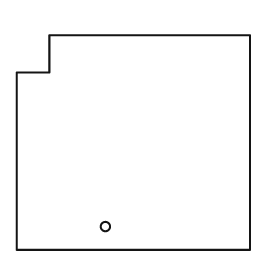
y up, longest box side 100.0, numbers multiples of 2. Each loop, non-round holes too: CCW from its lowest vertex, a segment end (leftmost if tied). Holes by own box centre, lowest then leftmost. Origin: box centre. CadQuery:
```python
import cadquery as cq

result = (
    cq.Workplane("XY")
    .moveTo(-50.0, -46.0)
    .lineTo(50.0, -46.0)
    .lineTo(50.0, 46.0)
    .lineTo(-36.0, 46.0)
    .lineTo(-36.0, 30.0)
    .lineTo(-50.0, 30.0)
    .close()
    .moveTo(-12.0, -36.0)
    .circle(2.0)
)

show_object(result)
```